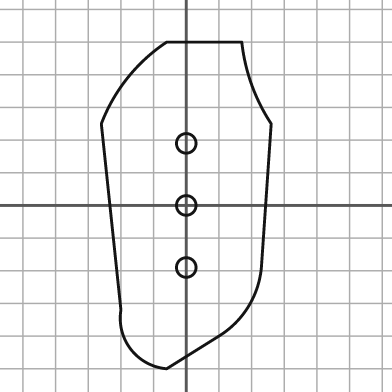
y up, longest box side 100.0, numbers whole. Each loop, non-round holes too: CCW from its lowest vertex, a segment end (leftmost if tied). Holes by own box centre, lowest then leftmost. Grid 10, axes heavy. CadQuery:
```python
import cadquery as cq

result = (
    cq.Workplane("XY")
    .moveTo(-6.0, -50.0)
    .lineTo(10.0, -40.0)
    .threePointArc((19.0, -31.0), (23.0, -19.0))
    .lineTo(26.0, 25.0)
    .threePointArc((20.0, 37.0), (17.0, 50.0))
    .lineTo(-6.0, 50.0)
    .threePointArc((-18.0, 39.0), (-26.0, 25.0))
    .lineTo(-20.0, -32.0)
    .threePointArc((-17.0, -44.0), (-6.0, -50.0))
    .close()
    .moveTo(0.0, -19.0)
    .circle(3.0)
    .moveTo(0.0, 0.0)
    .circle(3.0)
    .moveTo(0.0, 19.0)
    .circle(3.0)
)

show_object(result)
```